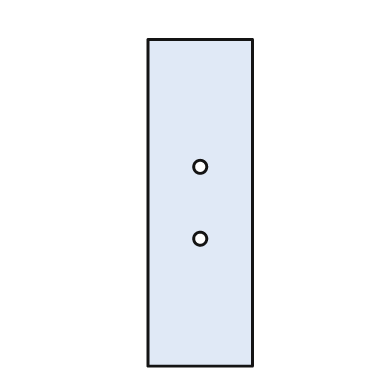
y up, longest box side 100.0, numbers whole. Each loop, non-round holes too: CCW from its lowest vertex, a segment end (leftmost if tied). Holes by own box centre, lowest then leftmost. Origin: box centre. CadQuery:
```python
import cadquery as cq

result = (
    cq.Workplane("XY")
    .moveTo(-16.0, -50.0)
    .lineTo(16.0, -50.0)
    .lineTo(16.0, 50.0)
    .lineTo(-16.0, 50.0)
    .close()
    .moveTo(0.0, -11.0)
    .circle(2.0)
    .moveTo(0.0, 11.0)
    .circle(2.0)
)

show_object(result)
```